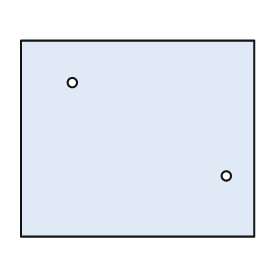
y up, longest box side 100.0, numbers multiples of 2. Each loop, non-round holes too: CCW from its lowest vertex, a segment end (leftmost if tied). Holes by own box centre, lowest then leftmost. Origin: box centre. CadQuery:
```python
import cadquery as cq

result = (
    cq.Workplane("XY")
    .moveTo(-50.0, -42.0)
    .lineTo(50.0, -42.0)
    .lineTo(50.0, 42.0)
    .lineTo(-50.0, 42.0)
    .close()
    .moveTo(38.0, -16.0)
    .circle(2.0)
    .moveTo(-28.0, 24.0)
    .circle(2.0)
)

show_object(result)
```